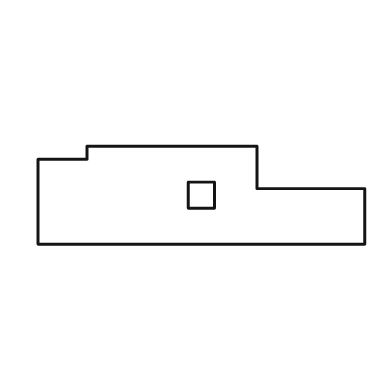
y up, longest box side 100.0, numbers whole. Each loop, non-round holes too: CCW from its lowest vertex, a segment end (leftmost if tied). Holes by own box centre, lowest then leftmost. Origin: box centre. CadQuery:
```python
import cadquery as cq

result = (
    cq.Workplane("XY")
    .moveTo(-50.0, -15.0)
    .lineTo(50.0, -15.0)
    .lineTo(50.0, 2.0)
    .lineTo(17.0, 2.0)
    .lineTo(17.0, 15.0)
    .lineTo(-35.0, 15.0)
    .lineTo(-35.0, 11.0)
    .lineTo(-50.0, 11.0)
    .close()
    .moveTo(-4.0, -4.0)
    .lineTo(4.0, -4.0)
    .lineTo(4.0, 4.0)
    .lineTo(-4.0, 4.0)
    .close()
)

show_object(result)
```